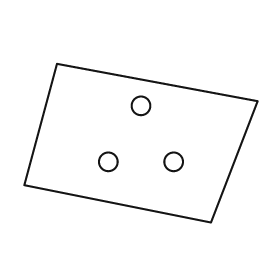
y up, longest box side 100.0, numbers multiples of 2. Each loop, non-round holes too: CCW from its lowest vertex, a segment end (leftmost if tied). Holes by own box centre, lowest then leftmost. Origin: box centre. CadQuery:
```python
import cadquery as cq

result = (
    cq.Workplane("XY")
    .moveTo(30.0, -34.0)
    .lineTo(50.0, 18.0)
    .lineTo(-36.0, 34.0)
    .lineTo(-50.0, -18.0)
    .close()
    .moveTo(-14.0, -8.0)
    .circle(4.0)
    .moveTo(14.0, -8.0)
    .circle(4.0)
    .moveTo(0.0, 16.0)
    .circle(4.0)
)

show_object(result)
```